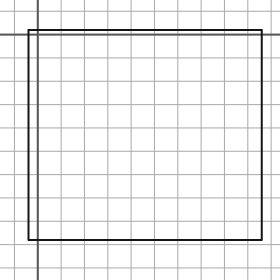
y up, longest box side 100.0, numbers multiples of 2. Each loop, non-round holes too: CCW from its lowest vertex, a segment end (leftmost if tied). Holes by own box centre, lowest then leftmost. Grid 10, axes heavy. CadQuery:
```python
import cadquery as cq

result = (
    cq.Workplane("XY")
    .moveTo(-4.0, -88.0)
    .lineTo(96.0, -88.0)
    .lineTo(96.0, 2.0)
    .lineTo(-4.0, 2.0)
    .close()
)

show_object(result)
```